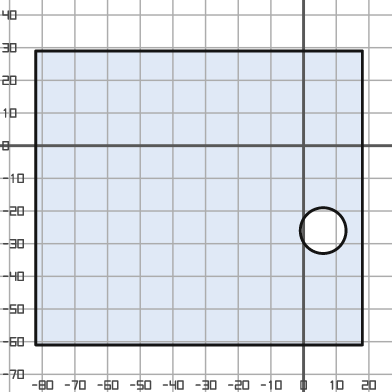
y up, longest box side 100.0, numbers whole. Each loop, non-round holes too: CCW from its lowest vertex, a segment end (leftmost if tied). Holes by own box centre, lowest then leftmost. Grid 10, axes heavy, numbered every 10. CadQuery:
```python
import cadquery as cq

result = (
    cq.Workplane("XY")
    .moveTo(-82.0, -61.0)
    .lineTo(18.0, -61.0)
    .lineTo(18.0, 29.0)
    .lineTo(-82.0, 29.0)
    .close()
    .moveTo(6.0, -26.0)
    .circle(7.0)
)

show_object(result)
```